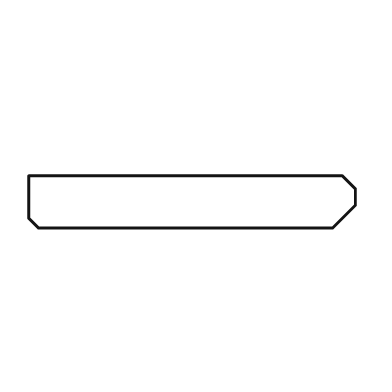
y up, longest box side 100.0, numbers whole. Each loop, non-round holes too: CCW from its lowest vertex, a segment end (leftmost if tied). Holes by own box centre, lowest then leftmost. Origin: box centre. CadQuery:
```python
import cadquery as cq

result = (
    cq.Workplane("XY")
    .moveTo(-47.0, -8.0)
    .lineTo(43.0, -8.0)
    .lineTo(50.0, -1.0)
    .lineTo(50.0, 4.0)
    .lineTo(46.0, 8.0)
    .lineTo(-50.0, 8.0)
    .lineTo(-50.0, -5.0)
    .close()
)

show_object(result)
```